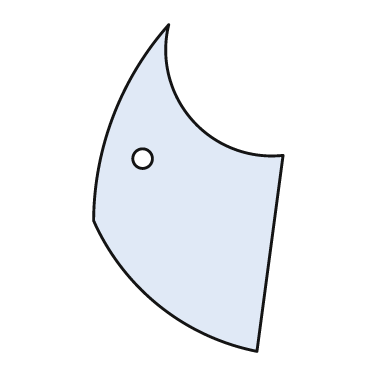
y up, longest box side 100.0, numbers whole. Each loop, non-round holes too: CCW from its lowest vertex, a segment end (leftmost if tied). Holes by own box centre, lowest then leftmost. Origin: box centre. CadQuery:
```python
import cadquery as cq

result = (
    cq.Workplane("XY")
    .moveTo(21.0, -50.0)
    .lineTo(29.0, 10.0)
    .threePointArc((1.0, 21.0), (-6.0, 50.0))
    .threePointArc((-23.0, 22.0), (-29.0, -10.0))
    .threePointArc((-9.0, -36.0), (21.0, -50.0))
    .close()
    .moveTo(-14.0, 9.0)
    .circle(3.0)
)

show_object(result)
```